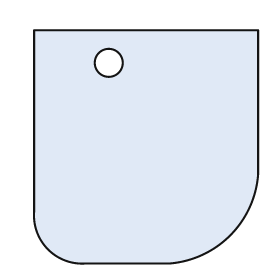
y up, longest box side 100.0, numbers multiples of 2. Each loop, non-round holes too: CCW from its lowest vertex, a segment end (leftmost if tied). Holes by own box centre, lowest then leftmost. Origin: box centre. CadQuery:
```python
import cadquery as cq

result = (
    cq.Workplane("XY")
    .moveTo(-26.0, -50.0)
    .lineTo(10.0, -50.0)
    .threePointArc((36.0, -38.0), (48.0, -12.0))
    .lineTo(48.0, 50.0)
    .lineTo(-48.0, 50.0)
    .lineTo(-48.0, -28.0)
    .threePointArc((-42.0, -44.0), (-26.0, -50.0))
    .close()
    .moveTo(-16.0, 36.0)
    .circle(6.0)
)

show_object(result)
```